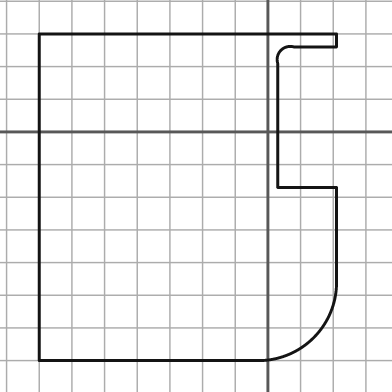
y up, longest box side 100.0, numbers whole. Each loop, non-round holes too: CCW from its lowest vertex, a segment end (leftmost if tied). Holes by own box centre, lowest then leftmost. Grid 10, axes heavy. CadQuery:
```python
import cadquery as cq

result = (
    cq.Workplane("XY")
    .moveTo(-70.0, -70.0)
    .lineTo(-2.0, -70.0)
    .threePointArc((14.0, -63.0), (21.0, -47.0))
    .lineTo(21.0, -17.0)
    .lineTo(3.0, -17.0)
    .lineTo(3.0, 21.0)
    .threePointArc((4.0, 25.0), (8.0, 26.0))
    .lineTo(21.0, 26.0)
    .lineTo(21.0, 30.0)
    .lineTo(-70.0, 30.0)
    .close()
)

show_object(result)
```